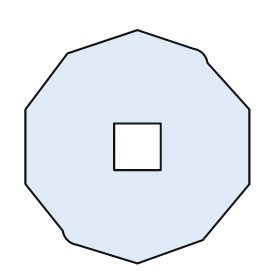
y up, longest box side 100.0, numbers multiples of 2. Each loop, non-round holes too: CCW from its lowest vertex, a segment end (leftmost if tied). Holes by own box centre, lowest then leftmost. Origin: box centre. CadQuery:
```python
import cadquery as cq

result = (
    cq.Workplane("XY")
    .moveTo(0.0, -50.0)
    .lineTo(28.0, -40.0)
    .lineTo(48.0, -16.0)
    .lineTo(48.0, 16.0)
    .lineTo(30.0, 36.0)
    .threePointArc((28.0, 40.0), (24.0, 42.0))
    .lineTo(0.0, 50.0)
    .lineTo(-30.0, 40.0)
    .lineTo(-48.0, 16.0)
    .lineTo(-48.0, -16.0)
    .lineTo(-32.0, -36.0)
    .threePointArc((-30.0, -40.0), (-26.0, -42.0))
    .close()
    .moveTo(-10.0, -10.0)
    .lineTo(10.0, -10.0)
    .lineTo(10.0, 10.0)
    .lineTo(-10.0, 10.0)
    .close()
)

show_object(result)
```